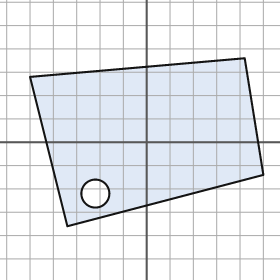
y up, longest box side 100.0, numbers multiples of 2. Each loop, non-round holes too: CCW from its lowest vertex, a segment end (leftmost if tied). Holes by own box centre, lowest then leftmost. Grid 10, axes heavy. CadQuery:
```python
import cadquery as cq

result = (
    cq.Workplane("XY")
    .moveTo(-34.0, -36.0)
    .lineTo(50.0, -14.0)
    .lineTo(42.0, 36.0)
    .lineTo(-50.0, 28.0)
    .close()
    .moveTo(-22.0, -22.0)
    .circle(6.0)
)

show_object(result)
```